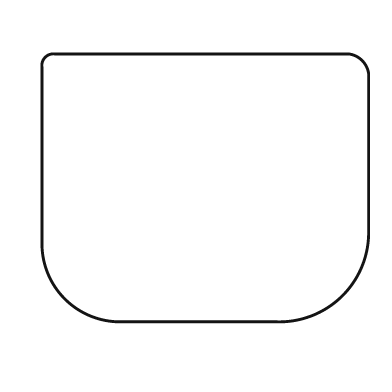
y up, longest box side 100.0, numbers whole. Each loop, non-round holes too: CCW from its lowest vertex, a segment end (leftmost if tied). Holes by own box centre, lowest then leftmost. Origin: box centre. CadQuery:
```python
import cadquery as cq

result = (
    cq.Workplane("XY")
    .moveTo(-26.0, -41.0)
    .lineTo(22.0, -41.0)
    .threePointArc((42.0, -33.0), (50.0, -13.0))
    .lineTo(50.0, 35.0)
    .threePointArc((48.0, 39.0), (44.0, 41.0))
    .lineTo(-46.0, 41.0)
    .threePointArc((-49.0, 40.0), (-50.0, 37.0))
    .lineTo(-50.0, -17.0)
    .threePointArc((-43.0, -34.0), (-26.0, -41.0))
    .close()
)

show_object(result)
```